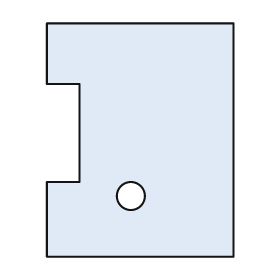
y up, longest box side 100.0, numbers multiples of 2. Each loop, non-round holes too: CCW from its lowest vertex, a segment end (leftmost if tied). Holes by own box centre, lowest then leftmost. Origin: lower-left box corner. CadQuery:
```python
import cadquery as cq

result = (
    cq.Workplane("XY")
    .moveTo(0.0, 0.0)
    .lineTo(80.0, 0.0)
    .lineTo(80.0, 100.0)
    .lineTo(0.0, 100.0)
    .lineTo(0.0, 74.0)
    .lineTo(14.0, 74.0)
    .lineTo(14.0, 32.0)
    .lineTo(0.0, 32.0)
    .close()
    .moveTo(36.0, 26.0)
    .circle(6.0)
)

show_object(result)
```